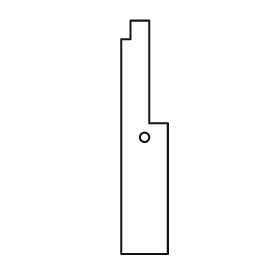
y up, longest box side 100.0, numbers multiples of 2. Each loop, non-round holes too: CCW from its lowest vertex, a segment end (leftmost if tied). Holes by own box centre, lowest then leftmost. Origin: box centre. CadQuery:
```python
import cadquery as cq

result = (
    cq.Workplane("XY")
    .moveTo(-10.0, -50.0)
    .lineTo(10.0, -50.0)
    .lineTo(10.0, 6.0)
    .lineTo(2.0, 6.0)
    .lineTo(2.0, 50.0)
    .lineTo(-6.0, 50.0)
    .lineTo(-6.0, 42.0)
    .lineTo(-10.0, 42.0)
    .close()
    .moveTo(0.0, 0.0)
    .circle(2.0)
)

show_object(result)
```